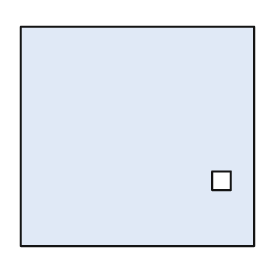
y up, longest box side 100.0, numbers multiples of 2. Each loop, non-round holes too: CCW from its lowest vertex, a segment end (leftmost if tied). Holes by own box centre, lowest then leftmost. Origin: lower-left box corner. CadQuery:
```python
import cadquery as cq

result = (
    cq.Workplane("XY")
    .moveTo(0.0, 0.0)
    .lineTo(100.0, 0.0)
    .lineTo(100.0, 94.0)
    .lineTo(0.0, 94.0)
    .close()
    .moveTo(82.0, 24.0)
    .lineTo(90.0, 24.0)
    .lineTo(90.0, 32.0)
    .lineTo(82.0, 32.0)
    .close()
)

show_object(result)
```